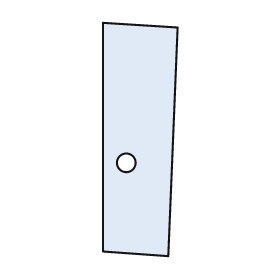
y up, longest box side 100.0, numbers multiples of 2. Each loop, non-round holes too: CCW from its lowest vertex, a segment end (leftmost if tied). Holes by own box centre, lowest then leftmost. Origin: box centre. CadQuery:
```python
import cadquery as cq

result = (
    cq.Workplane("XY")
    .moveTo(12.0, -50.0)
    .lineTo(16.0, 48.0)
    .lineTo(-16.0, 50.0)
    .lineTo(-16.0, -48.0)
    .close()
    .moveTo(-6.0, -10.0)
    .circle(4.0)
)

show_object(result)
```